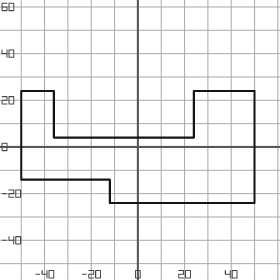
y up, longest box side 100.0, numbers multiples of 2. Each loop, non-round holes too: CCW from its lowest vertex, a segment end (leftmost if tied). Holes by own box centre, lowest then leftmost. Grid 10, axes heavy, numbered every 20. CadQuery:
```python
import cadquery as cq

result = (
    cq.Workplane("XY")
    .moveTo(-12.0, -24.0)
    .lineTo(50.0, -24.0)
    .lineTo(50.0, 24.0)
    .lineTo(24.0, 24.0)
    .lineTo(24.0, 4.0)
    .lineTo(-36.0, 4.0)
    .lineTo(-36.0, 24.0)
    .lineTo(-50.0, 24.0)
    .lineTo(-50.0, -14.0)
    .lineTo(-12.0, -14.0)
    .close()
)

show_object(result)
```